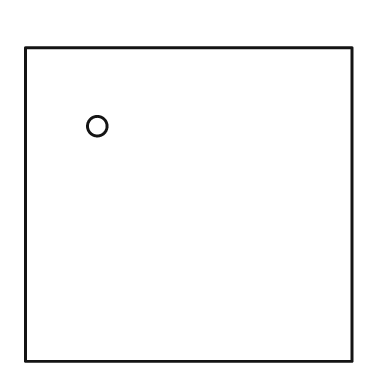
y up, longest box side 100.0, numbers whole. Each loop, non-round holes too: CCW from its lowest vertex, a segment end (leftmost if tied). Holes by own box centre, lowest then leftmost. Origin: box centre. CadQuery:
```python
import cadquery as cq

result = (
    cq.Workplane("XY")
    .moveTo(-50.0, -48.0)
    .lineTo(50.0, -48.0)
    .lineTo(50.0, 48.0)
    .lineTo(-50.0, 48.0)
    .close()
    .moveTo(-28.0, 24.0)
    .circle(3.0)
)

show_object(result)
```